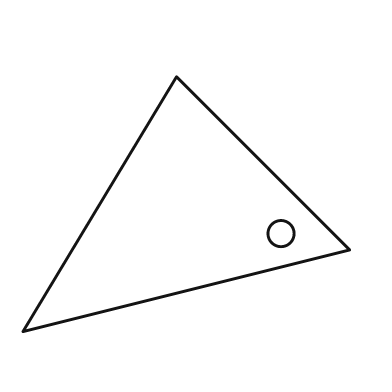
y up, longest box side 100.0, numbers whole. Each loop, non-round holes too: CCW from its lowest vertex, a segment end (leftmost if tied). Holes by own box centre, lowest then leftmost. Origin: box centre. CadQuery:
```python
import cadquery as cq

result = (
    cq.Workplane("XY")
    .moveTo(-50.0, -39.0)
    .lineTo(50.0, -14.0)
    .lineTo(-3.0, 39.0)
    .close()
    .moveTo(29.0, -9.0)
    .circle(4.0)
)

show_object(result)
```